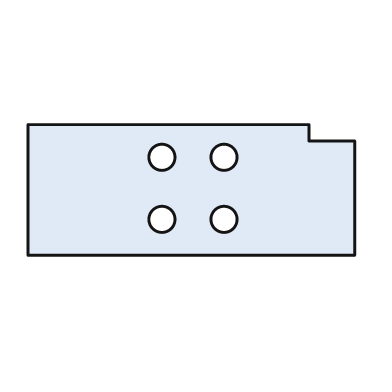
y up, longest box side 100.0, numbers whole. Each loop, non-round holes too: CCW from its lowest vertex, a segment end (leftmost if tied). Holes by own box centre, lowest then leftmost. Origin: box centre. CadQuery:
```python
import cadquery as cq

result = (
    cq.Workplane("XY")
    .moveTo(-50.0, -20.0)
    .lineTo(50.0, -20.0)
    .lineTo(50.0, 15.0)
    .lineTo(36.0, 15.0)
    .lineTo(36.0, 20.0)
    .lineTo(-50.0, 20.0)
    .close()
    .moveTo(-9.0, -9.0)
    .circle(4.0)
    .moveTo(10.0, -9.0)
    .circle(4.0)
    .moveTo(-9.0, 10.0)
    .circle(4.0)
    .moveTo(10.0, 10.0)
    .circle(4.0)
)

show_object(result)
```